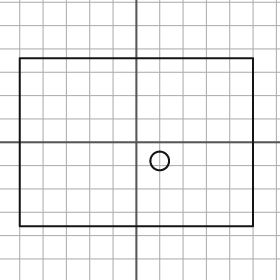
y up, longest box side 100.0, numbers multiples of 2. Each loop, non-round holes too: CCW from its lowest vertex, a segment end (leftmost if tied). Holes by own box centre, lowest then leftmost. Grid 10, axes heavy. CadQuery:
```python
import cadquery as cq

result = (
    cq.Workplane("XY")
    .moveTo(-50.0, -36.0)
    .lineTo(50.0, -36.0)
    .lineTo(50.0, 36.0)
    .lineTo(-50.0, 36.0)
    .close()
    .moveTo(10.0, -8.0)
    .circle(4.0)
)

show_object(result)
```